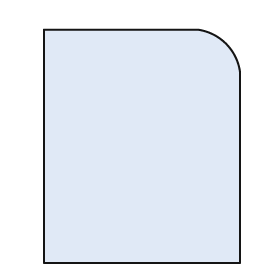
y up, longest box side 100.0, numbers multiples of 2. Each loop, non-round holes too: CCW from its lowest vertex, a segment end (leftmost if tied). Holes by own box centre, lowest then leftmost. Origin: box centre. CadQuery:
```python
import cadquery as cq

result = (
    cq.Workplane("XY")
    .moveTo(-42.0, -50.0)
    .lineTo(42.0, -50.0)
    .lineTo(42.0, 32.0)
    .threePointArc((36.0, 44.0), (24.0, 50.0))
    .lineTo(-42.0, 50.0)
    .close()
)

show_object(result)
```